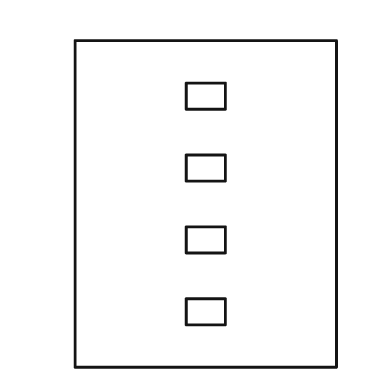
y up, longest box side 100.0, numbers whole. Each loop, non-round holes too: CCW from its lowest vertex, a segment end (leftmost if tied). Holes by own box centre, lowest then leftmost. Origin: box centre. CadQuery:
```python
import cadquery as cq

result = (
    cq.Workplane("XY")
    .moveTo(-40.0, -50.0)
    .lineTo(40.0, -50.0)
    .lineTo(40.0, 50.0)
    .lineTo(-40.0, 50.0)
    .close()
    .moveTo(-6.0, -37.0)
    .lineTo(6.0, -37.0)
    .lineTo(6.0, -29.0)
    .lineTo(-6.0, -29.0)
    .close()
    .moveTo(-6.0, -15.0)
    .lineTo(6.0, -15.0)
    .lineTo(6.0, -7.0)
    .lineTo(-6.0, -7.0)
    .close()
    .moveTo(-6.0, 7.0)
    .lineTo(6.0, 7.0)
    .lineTo(6.0, 15.0)
    .lineTo(-6.0, 15.0)
    .close()
    .moveTo(-6.0, 29.0)
    .lineTo(6.0, 29.0)
    .lineTo(6.0, 37.0)
    .lineTo(-6.0, 37.0)
    .close()
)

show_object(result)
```